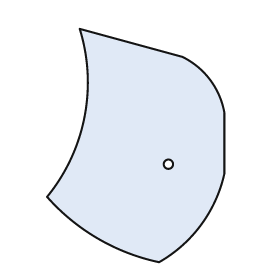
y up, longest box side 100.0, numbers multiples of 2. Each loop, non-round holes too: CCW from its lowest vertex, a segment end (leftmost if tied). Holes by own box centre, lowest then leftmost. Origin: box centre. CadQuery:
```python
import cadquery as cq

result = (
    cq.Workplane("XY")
    .moveTo(10.0, -50.0)
    .threePointArc((28.0, -34.0), (38.0, -12.0))
    .lineTo(38.0, 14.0)
    .threePointArc((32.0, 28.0), (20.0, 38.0))
    .lineTo(-24.0, 50.0)
    .threePointArc((-22.0, 12.0), (-38.0, -22.0))
    .threePointArc((-16.0, -40.0), (10.0, -50.0))
    .close()
    .moveTo(14.0, -8.0)
    .circle(2.0)
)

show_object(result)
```